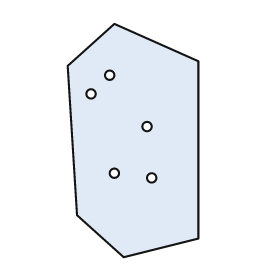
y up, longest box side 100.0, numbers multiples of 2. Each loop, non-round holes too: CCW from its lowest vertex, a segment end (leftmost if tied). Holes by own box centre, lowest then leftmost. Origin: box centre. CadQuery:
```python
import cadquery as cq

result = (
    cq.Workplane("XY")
    .moveTo(-4.0, -50.0)
    .lineTo(28.0, -42.0)
    .lineTo(28.0, 34.0)
    .lineTo(-8.0, 50.0)
    .lineTo(-28.0, 32.0)
    .lineTo(-24.0, -32.0)
    .close()
    .moveTo(8.0, -16.0)
    .circle(2.0)
    .moveTo(-8.0, -14.0)
    .circle(2.0)
    .moveTo(6.0, 6.0)
    .circle(2.0)
    .moveTo(-18.0, 20.0)
    .circle(2.0)
    .moveTo(-10.0, 28.0)
    .circle(2.0)
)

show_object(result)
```